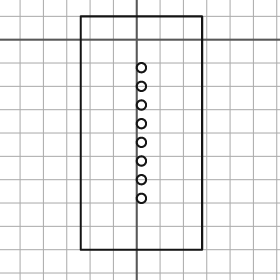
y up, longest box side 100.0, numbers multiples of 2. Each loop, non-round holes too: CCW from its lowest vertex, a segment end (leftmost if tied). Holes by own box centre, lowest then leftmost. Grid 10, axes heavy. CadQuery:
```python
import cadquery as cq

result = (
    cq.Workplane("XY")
    .moveTo(-24.0, -90.0)
    .lineTo(28.0, -90.0)
    .lineTo(28.0, 10.0)
    .lineTo(-24.0, 10.0)
    .close()
    .moveTo(2.0, -68.0)
    .circle(2.0)
    .moveTo(2.0, -60.0)
    .circle(2.0)
    .moveTo(2.0, -52.0)
    .circle(2.0)
    .moveTo(2.0, -44.0)
    .circle(2.0)
    .moveTo(2.0, -36.0)
    .circle(2.0)
    .moveTo(2.0, -28.0)
    .circle(2.0)
    .moveTo(2.0, -20.0)
    .circle(2.0)
    .moveTo(2.0, -12.0)
    .circle(2.0)
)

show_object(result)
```